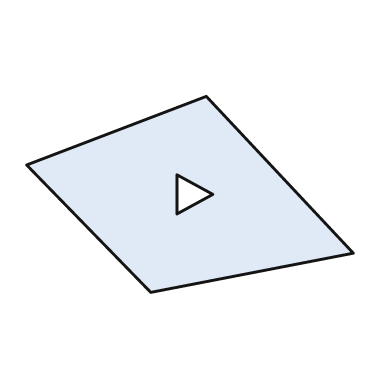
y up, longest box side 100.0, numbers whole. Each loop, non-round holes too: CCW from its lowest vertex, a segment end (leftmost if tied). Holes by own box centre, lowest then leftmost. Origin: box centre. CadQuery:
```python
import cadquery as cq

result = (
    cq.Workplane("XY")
    .moveTo(-12.0, -30.0)
    .lineTo(50.0, -18.0)
    .lineTo(5.0, 30.0)
    .lineTo(-50.0, 9.0)
    .close()
    .moveTo(-4.0, -6.0)
    .lineTo(7.0, 0.0)
    .lineTo(-4.0, 6.0)
    .close()
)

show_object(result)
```